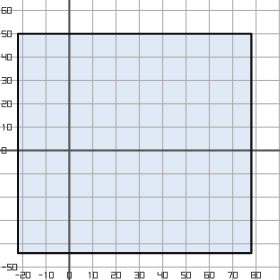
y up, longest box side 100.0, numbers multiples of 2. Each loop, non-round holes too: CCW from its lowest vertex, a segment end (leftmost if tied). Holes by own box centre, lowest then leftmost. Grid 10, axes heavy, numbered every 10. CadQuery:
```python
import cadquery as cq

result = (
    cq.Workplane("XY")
    .moveTo(-22.0, -44.0)
    .lineTo(78.0, -44.0)
    .lineTo(78.0, 50.0)
    .lineTo(-22.0, 50.0)
    .close()
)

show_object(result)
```